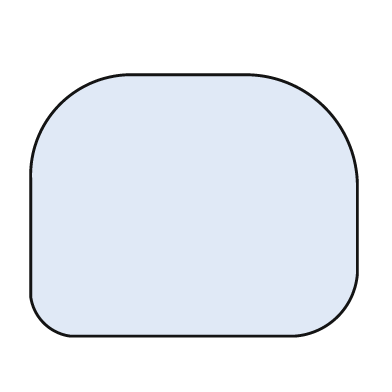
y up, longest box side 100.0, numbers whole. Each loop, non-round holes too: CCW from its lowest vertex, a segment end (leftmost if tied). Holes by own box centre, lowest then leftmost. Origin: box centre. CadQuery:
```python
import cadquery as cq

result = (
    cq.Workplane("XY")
    .moveTo(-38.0, -40.0)
    .lineTo(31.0, -40.0)
    .threePointArc((44.0, -34.0), (50.0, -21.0))
    .lineTo(50.0, 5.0)
    .threePointArc((40.0, 30.0), (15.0, 40.0))
    .lineTo(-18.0, 40.0)
    .threePointArc((-41.0, 31.0), (-50.0, 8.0))
    .lineTo(-50.0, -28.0)
    .threePointArc((-46.0, -36.0), (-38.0, -40.0))
    .close()
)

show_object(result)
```